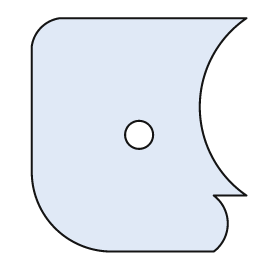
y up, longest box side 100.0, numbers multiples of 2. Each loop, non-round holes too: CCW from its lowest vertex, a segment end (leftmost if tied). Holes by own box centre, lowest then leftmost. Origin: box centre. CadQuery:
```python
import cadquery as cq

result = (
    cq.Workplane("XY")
    .moveTo(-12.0, -50.0)
    .lineTo(32.0, -50.0)
    .threePointArc((38.0, -38.0), (32.0, -26.0))
    .lineTo(46.0, -26.0)
    .threePointArc((26.0, 12.0), (46.0, 50.0))
    .lineTo(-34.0, 50.0)
    .threePointArc((-42.0, 46.0), (-46.0, 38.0))
    .lineTo(-46.0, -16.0)
    .threePointArc((-36.0, -40.0), (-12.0, -50.0))
    .close()
    .moveTo(0.0, 0.0)
    .circle(6.0)
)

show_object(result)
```